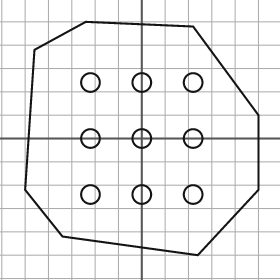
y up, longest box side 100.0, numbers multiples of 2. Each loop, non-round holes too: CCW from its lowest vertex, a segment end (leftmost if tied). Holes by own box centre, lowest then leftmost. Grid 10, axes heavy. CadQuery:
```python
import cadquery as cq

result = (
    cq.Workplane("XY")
    .moveTo(24.0, -50.0)
    .lineTo(50.0, -22.0)
    .lineTo(50.0, 10.0)
    .lineTo(22.0, 48.0)
    .lineTo(-24.0, 50.0)
    .lineTo(-46.0, 38.0)
    .lineTo(-50.0, -22.0)
    .lineTo(-34.0, -42.0)
    .close()
    .moveTo(-22.0, -24.0)
    .circle(4.0)
    .moveTo(0.0, -24.0)
    .circle(4.0)
    .moveTo(22.0, -24.0)
    .circle(4.0)
    .moveTo(-22.0, 0.0)
    .circle(4.0)
    .moveTo(0.0, 0.0)
    .circle(4.0)
    .moveTo(22.0, 0.0)
    .circle(4.0)
    .moveTo(-22.0, 24.0)
    .circle(4.0)
    .moveTo(0.0, 24.0)
    .circle(4.0)
    .moveTo(22.0, 24.0)
    .circle(4.0)
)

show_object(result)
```